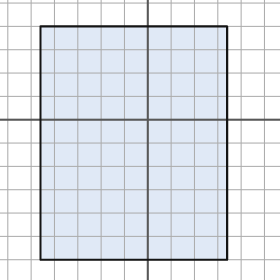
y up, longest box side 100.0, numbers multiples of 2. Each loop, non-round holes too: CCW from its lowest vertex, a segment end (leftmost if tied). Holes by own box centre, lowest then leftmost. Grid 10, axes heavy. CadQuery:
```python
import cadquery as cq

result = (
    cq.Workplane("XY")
    .moveTo(-46.0, -60.0)
    .lineTo(34.0, -60.0)
    .lineTo(34.0, 40.0)
    .lineTo(-46.0, 40.0)
    .close()
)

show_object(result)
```